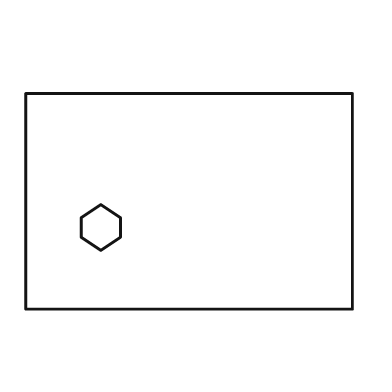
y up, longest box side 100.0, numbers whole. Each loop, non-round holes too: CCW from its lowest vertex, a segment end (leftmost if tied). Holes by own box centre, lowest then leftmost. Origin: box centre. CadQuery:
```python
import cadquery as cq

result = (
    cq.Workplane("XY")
    .moveTo(-50.0, -33.0)
    .lineTo(50.0, -33.0)
    .lineTo(50.0, 33.0)
    .lineTo(-50.0, 33.0)
    .close()
    .moveTo(-27.0, -15.0)
    .lineTo(-21.0, -11.0)
    .lineTo(-21.0, -5.0)
    .lineTo(-27.0, -1.0)
    .lineTo(-33.0, -5.0)
    .lineTo(-33.0, -11.0)
    .close()
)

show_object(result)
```